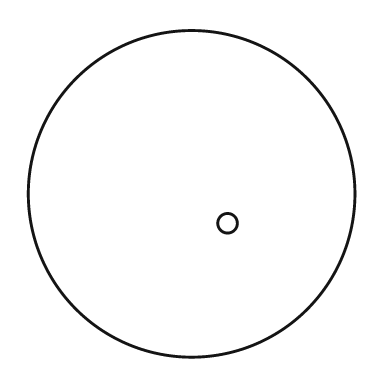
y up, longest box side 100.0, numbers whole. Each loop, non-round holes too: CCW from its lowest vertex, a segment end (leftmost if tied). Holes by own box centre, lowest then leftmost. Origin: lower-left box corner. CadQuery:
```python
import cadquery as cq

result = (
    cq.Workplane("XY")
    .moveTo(50.0, 50.0)
    .circle(50.0)
    .moveTo(61.0, 41.0)
    .circle(3.0)
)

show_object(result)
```